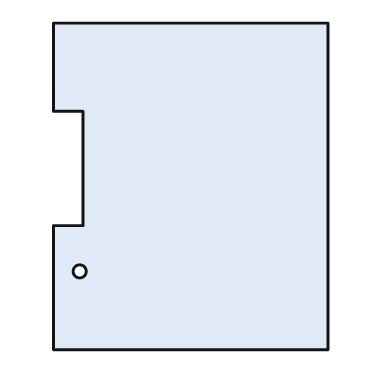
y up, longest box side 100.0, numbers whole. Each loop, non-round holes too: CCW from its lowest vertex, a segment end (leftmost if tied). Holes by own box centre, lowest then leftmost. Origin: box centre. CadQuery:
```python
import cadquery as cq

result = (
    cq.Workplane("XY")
    .moveTo(-42.0, -50.0)
    .lineTo(42.0, -50.0)
    .lineTo(42.0, 50.0)
    .lineTo(-42.0, 50.0)
    .lineTo(-42.0, 23.0)
    .lineTo(-33.0, 23.0)
    .lineTo(-33.0, -12.0)
    .lineTo(-42.0, -12.0)
    .close()
    .moveTo(-34.0, -26.0)
    .circle(2.0)
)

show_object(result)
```